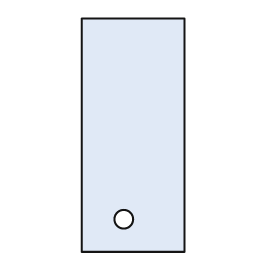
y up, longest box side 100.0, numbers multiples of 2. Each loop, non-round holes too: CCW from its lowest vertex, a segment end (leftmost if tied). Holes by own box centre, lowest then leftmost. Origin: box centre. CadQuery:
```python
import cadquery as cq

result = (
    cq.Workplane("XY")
    .moveTo(-22.0, -50.0)
    .lineTo(22.0, -50.0)
    .lineTo(22.0, 50.0)
    .lineTo(-22.0, 50.0)
    .close()
    .moveTo(-4.0, -36.0)
    .circle(4.0)
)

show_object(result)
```